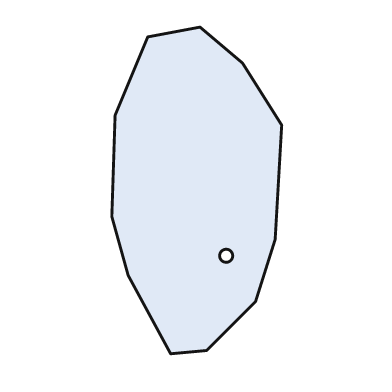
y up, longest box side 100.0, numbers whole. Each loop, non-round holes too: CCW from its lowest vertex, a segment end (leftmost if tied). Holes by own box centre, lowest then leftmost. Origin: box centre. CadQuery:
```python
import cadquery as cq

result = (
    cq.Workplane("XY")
    .moveTo(-8.0, -50.0)
    .lineTo(3.0, -49.0)
    .lineTo(18.0, -34.0)
    .lineTo(24.0, -15.0)
    .lineTo(26.0, 20.0)
    .lineTo(14.0, 39.0)
    .lineTo(1.0, 50.0)
    .lineTo(-15.0, 47.0)
    .lineTo(-25.0, 23.0)
    .lineTo(-26.0, -8.0)
    .lineTo(-21.0, -26.0)
    .close()
    .moveTo(9.0, -20.0)
    .circle(2.0)
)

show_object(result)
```